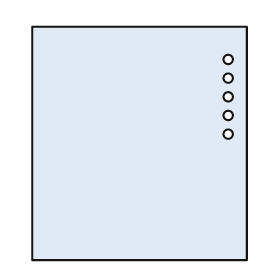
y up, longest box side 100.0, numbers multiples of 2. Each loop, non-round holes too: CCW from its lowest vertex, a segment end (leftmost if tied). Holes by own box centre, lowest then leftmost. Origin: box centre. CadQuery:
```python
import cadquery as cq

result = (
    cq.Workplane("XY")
    .moveTo(-46.0, -50.0)
    .lineTo(46.0, -50.0)
    .lineTo(46.0, 50.0)
    .lineTo(-46.0, 50.0)
    .close()
    .moveTo(38.0, 4.0)
    .circle(2.0)
    .moveTo(38.0, 12.0)
    .circle(2.0)
    .moveTo(38.0, 20.0)
    .circle(2.0)
    .moveTo(38.0, 28.0)
    .circle(2.0)
    .moveTo(38.0, 36.0)
    .circle(2.0)
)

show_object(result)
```